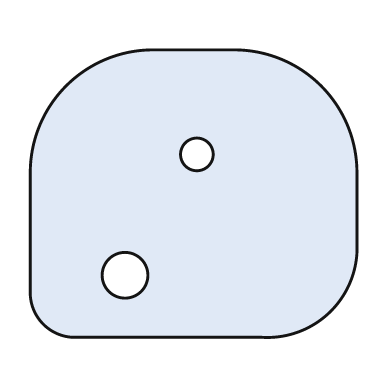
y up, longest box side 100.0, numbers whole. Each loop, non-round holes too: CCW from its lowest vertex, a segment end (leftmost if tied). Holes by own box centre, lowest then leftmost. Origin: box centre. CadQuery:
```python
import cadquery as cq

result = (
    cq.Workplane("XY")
    .moveTo(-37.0, -44.0)
    .lineTo(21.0, -44.0)
    .threePointArc((42.0, -36.0), (50.0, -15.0))
    .lineTo(50.0, 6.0)
    .threePointArc((39.0, 33.0), (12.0, 44.0))
    .lineTo(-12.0, 44.0)
    .threePointArc((-39.0, 33.0), (-50.0, 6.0))
    .lineTo(-50.0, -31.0)
    .threePointArc((-46.0, -40.0), (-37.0, -44.0))
    .close()
    .moveTo(-21.0, -25.0)
    .circle(7.0)
    .moveTo(1.0, 12.0)
    .circle(5.0)
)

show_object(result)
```